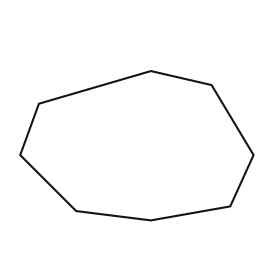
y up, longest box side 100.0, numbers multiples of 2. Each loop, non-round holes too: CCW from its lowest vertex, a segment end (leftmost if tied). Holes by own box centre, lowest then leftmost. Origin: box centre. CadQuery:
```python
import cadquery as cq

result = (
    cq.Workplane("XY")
    .moveTo(6.0, -32.0)
    .lineTo(40.0, -26.0)
    .lineTo(50.0, -4.0)
    .lineTo(32.0, 26.0)
    .lineTo(6.0, 32.0)
    .lineTo(-42.0, 18.0)
    .lineTo(-50.0, -4.0)
    .lineTo(-26.0, -28.0)
    .close()
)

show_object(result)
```